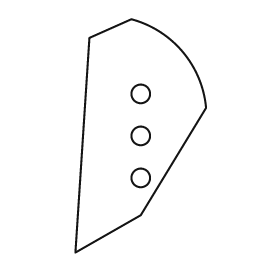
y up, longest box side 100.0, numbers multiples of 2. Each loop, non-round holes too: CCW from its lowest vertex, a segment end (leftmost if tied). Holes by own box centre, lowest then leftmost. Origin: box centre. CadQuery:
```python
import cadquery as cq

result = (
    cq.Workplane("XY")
    .moveTo(-28.0, -50.0)
    .lineTo(0.0, -34.0)
    .lineTo(28.0, 12.0)
    .threePointArc((18.0, 36.0), (-4.0, 50.0))
    .lineTo(-22.0, 42.0)
    .close()
    .moveTo(0.0, -18.0)
    .circle(4.0)
    .moveTo(0.0, 0.0)
    .circle(4.0)
    .moveTo(0.0, 18.0)
    .circle(4.0)
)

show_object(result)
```